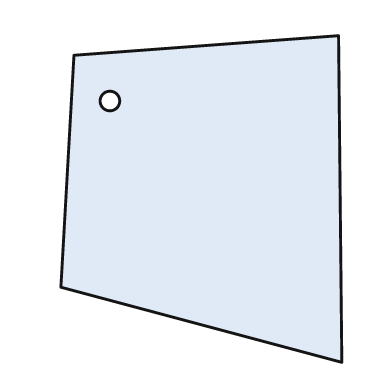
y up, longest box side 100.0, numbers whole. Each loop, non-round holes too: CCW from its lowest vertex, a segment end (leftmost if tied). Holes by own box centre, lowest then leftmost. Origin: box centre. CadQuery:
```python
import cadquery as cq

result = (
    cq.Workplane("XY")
    .moveTo(43.0, -50.0)
    .lineTo(42.0, 50.0)
    .lineTo(-39.0, 44.0)
    .lineTo(-43.0, -27.0)
    .close()
    .moveTo(-28.0, 30.0)
    .circle(3.0)
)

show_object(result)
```